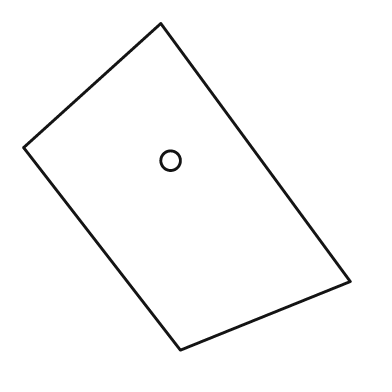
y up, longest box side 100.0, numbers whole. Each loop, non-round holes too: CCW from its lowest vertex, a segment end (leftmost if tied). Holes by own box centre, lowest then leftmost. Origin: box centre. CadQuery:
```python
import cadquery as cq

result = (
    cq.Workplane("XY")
    .moveTo(-2.0, -50.0)
    .lineTo(50.0, -29.0)
    .lineTo(-8.0, 50.0)
    .lineTo(-50.0, 12.0)
    .close()
    .moveTo(-5.0, 8.0)
    .circle(3.0)
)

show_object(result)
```